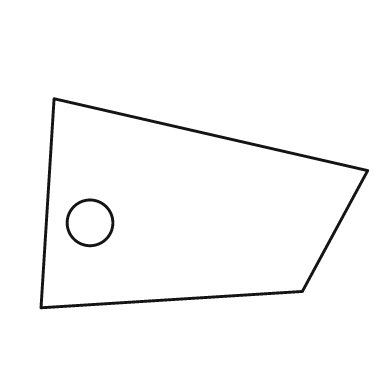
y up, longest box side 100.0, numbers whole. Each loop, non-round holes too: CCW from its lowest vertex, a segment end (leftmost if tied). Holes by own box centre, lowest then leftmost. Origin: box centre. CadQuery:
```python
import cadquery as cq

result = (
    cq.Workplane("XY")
    .moveTo(-50.0, -32.0)
    .lineTo(30.0, -27.0)
    .lineTo(50.0, 10.0)
    .lineTo(-46.0, 32.0)
    .close()
    .moveTo(-35.0, -6.0)
    .circle(7.0)
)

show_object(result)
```